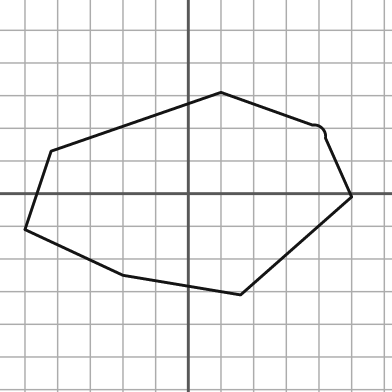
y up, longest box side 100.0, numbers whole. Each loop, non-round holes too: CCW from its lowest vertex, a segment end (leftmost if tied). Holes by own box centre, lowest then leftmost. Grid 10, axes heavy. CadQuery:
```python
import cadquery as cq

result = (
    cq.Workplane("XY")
    .moveTo(16.0, -31.0)
    .lineTo(50.0, -1.0)
    .lineTo(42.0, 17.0)
    .threePointArc((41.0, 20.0), (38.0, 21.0))
    .lineTo(10.0, 31.0)
    .lineTo(-42.0, 13.0)
    .lineTo(-50.0, -11.0)
    .lineTo(-20.0, -25.0)
    .close()
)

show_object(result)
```